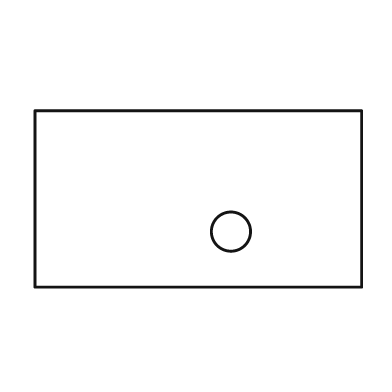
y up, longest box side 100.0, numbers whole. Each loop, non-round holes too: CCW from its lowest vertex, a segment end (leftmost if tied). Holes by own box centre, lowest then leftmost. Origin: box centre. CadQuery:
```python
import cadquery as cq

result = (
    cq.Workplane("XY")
    .moveTo(-50.0, -27.0)
    .lineTo(50.0, -27.0)
    .lineTo(50.0, 27.0)
    .lineTo(-50.0, 27.0)
    .close()
    .moveTo(10.0, -10.0)
    .circle(6.0)
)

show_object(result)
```